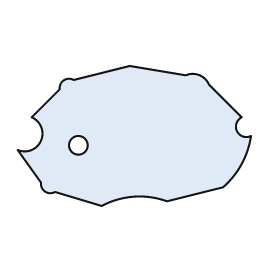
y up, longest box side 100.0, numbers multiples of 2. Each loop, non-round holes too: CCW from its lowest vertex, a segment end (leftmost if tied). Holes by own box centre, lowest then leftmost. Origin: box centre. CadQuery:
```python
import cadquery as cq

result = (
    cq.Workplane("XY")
    .moveTo(-14.0, -30.0)
    .threePointArc((0.0, -26.0), (14.0, -28.0))
    .lineTo(38.0, -22.0)
    .threePointArc((46.0, -12.0), (50.0, 0.0))
    .threePointArc((44.0, 2.0), (46.0, 8.0))
    .lineTo(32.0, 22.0)
    .threePointArc((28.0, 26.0), (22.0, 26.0))
    .lineTo(-2.0, 30.0)
    .lineTo(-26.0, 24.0)
    .threePointArc((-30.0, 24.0), (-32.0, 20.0))
    .lineTo(-44.0, 8.0)
    .threePointArc((-40.0, -2.0), (-50.0, -6.0))
    .lineTo(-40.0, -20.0)
    .threePointArc((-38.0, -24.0), (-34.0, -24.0))
    .close()
    .moveTo(-24.0, -4.0)
    .circle(4.0)
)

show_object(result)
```